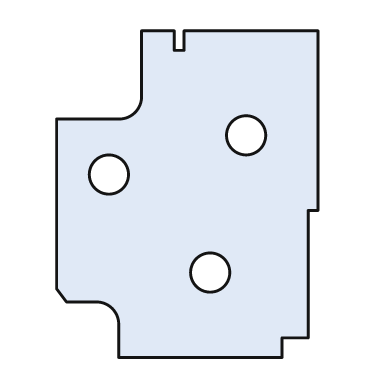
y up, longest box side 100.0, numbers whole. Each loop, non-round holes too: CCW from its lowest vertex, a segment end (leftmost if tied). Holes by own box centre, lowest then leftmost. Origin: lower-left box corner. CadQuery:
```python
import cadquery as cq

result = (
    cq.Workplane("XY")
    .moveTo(19.0, 0.0)
    .lineTo(69.0, 0.0)
    .lineTo(69.0, 6.0)
    .lineTo(77.0, 6.0)
    .lineTo(77.0, 45.0)
    .lineTo(80.0, 45.0)
    .lineTo(80.0, 100.0)
    .lineTo(39.0, 100.0)
    .lineTo(39.0, 94.0)
    .lineTo(36.0, 94.0)
    .lineTo(36.0, 100.0)
    .lineTo(26.0, 100.0)
    .lineTo(26.0, 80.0)
    .threePointArc((24.0, 75.0), (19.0, 73.0))
    .lineTo(0.0, 73.0)
    .lineTo(0.0, 21.0)
    .lineTo(3.0, 17.0)
    .lineTo(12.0, 17.0)
    .threePointArc((17.0, 15.0), (19.0, 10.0))
    .close()
    .moveTo(47.0, 26.0)
    .circle(6.0)
    .moveTo(16.0, 56.0)
    .circle(6.0)
    .moveTo(58.0, 68.0)
    .circle(6.0)
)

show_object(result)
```